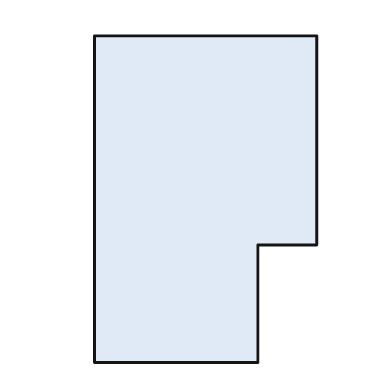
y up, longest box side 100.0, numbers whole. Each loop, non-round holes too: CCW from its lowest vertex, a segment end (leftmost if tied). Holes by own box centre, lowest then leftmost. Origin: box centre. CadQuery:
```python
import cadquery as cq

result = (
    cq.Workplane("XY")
    .moveTo(-34.0, -50.0)
    .lineTo(16.0, -50.0)
    .lineTo(16.0, -14.0)
    .lineTo(34.0, -14.0)
    .lineTo(34.0, 50.0)
    .lineTo(-34.0, 50.0)
    .close()
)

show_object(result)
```